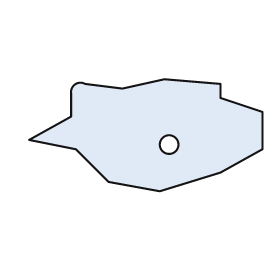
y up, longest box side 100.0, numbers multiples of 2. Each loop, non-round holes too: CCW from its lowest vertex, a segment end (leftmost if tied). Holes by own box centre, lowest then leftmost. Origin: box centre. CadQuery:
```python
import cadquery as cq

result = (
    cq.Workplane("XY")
    .moveTo(6.0, -24.0)
    .lineTo(32.0, -16.0)
    .lineTo(50.0, -6.0)
    .lineTo(50.0, 10.0)
    .lineTo(32.0, 16.0)
    .lineTo(32.0, 22.0)
    .lineTo(8.0, 24.0)
    .lineTo(-10.0, 20.0)
    .lineTo(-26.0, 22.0)
    .threePointArc((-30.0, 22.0), (-32.0, 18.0))
    .lineTo(-32.0, 8.0)
    .lineTo(-50.0, -2.0)
    .lineTo(-30.0, -6.0)
    .lineTo(-16.0, -20.0)
    .close()
    .moveTo(10.0, -4.0)
    .circle(4.0)
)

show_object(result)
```